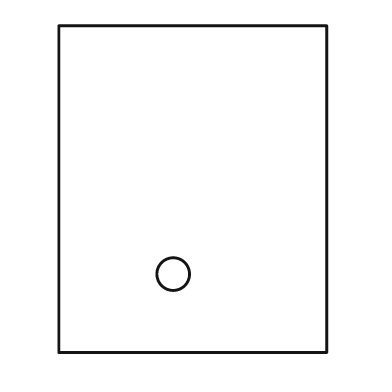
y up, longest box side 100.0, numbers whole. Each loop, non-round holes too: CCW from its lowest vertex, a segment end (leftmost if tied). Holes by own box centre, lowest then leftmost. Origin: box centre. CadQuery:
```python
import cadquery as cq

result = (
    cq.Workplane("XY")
    .moveTo(-41.0, -50.0)
    .lineTo(41.0, -50.0)
    .lineTo(41.0, 50.0)
    .lineTo(-41.0, 50.0)
    .close()
    .moveTo(-6.0, -26.0)
    .circle(5.0)
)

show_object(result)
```